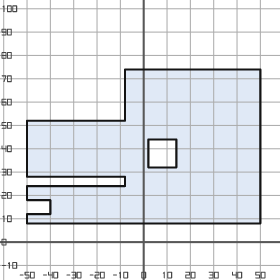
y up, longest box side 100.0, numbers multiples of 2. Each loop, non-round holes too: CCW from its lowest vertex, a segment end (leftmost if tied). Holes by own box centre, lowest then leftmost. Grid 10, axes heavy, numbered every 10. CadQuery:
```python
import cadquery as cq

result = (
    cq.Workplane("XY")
    .moveTo(-50.0, 8.0)
    .lineTo(50.0, 8.0)
    .lineTo(50.0, 74.0)
    .lineTo(-8.0, 74.0)
    .lineTo(-8.0, 52.0)
    .lineTo(-50.0, 52.0)
    .lineTo(-50.0, 28.0)
    .lineTo(-8.0, 28.0)
    .lineTo(-8.0, 24.0)
    .lineTo(-50.0, 24.0)
    .lineTo(-50.0, 18.0)
    .lineTo(-40.0, 18.0)
    .lineTo(-40.0, 12.0)
    .lineTo(-50.0, 12.0)
    .close()
    .moveTo(2.0, 32.0)
    .lineTo(14.0, 32.0)
    .lineTo(14.0, 44.0)
    .lineTo(2.0, 44.0)
    .close()
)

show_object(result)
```